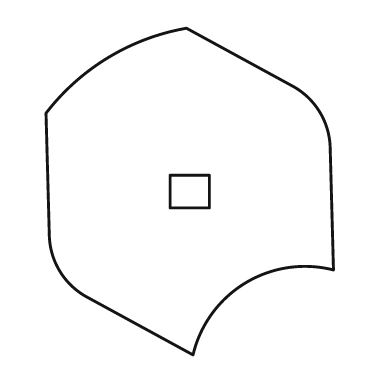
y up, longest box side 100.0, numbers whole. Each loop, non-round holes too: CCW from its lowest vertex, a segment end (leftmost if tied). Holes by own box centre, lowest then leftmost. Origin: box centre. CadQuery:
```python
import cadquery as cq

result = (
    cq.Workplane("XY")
    .moveTo(1.0, -50.0)
    .threePointArc((17.0, -28.0), (44.0, -24.0))
    .lineTo(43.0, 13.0)
    .threePointArc((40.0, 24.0), (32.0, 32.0))
    .lineTo(-1.0, 50.0)
    .threePointArc((-25.0, 41.0), (-44.0, 24.0))
    .lineTo(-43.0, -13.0)
    .threePointArc((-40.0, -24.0), (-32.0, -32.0))
    .close()
    .moveTo(-6.0, -5.0)
    .lineTo(6.0, -5.0)
    .lineTo(6.0, 5.0)
    .lineTo(-6.0, 5.0)
    .close()
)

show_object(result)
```